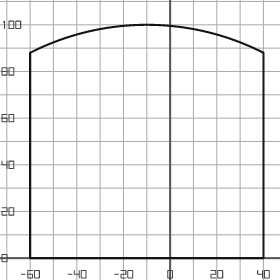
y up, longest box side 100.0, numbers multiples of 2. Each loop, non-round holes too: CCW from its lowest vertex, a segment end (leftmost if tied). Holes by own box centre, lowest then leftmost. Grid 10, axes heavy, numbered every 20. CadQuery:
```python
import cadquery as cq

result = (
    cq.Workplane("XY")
    .moveTo(-60.0, 0.0)
    .lineTo(40.0, 0.0)
    .lineTo(40.0, 88.0)
    .threePointArc((-10.0, 100.0), (-60.0, 88.0))
    .close()
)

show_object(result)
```